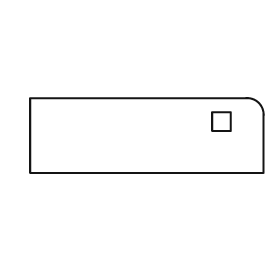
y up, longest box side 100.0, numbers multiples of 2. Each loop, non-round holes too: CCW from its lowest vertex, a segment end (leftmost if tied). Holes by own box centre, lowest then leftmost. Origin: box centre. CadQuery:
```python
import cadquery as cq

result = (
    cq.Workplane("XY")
    .moveTo(-50.0, -16.0)
    .lineTo(50.0, -16.0)
    .lineTo(50.0, 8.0)
    .threePointArc((48.0, 14.0), (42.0, 16.0))
    .lineTo(-50.0, 16.0)
    .close()
    .moveTo(28.0, 2.0)
    .lineTo(36.0, 2.0)
    .lineTo(36.0, 10.0)
    .lineTo(28.0, 10.0)
    .close()
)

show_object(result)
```